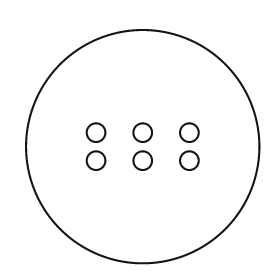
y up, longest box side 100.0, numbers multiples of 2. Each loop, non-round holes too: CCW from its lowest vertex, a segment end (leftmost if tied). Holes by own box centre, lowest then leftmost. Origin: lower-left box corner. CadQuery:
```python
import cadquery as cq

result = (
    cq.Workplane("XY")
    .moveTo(50.0, 50.0)
    .circle(50.0)
    .moveTo(30.0, 44.0)
    .circle(4.0)
    .moveTo(50.0, 44.0)
    .circle(4.0)
    .moveTo(70.0, 44.0)
    .circle(4.0)
    .moveTo(30.0, 56.0)
    .circle(4.0)
    .moveTo(50.0, 56.0)
    .circle(4.0)
    .moveTo(70.0, 56.0)
    .circle(4.0)
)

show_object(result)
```